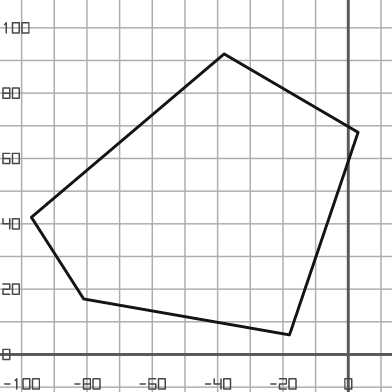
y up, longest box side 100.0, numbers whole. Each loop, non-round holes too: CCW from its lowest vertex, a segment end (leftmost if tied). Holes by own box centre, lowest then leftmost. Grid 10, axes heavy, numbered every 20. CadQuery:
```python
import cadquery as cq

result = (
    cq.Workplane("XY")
    .moveTo(-18.0, 6.0)
    .lineTo(3.0, 68.0)
    .lineTo(-38.0, 92.0)
    .lineTo(-97.0, 42.0)
    .lineTo(-81.0, 17.0)
    .close()
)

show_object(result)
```